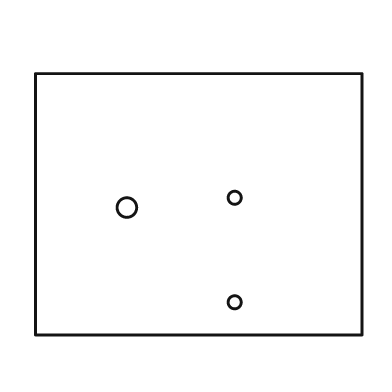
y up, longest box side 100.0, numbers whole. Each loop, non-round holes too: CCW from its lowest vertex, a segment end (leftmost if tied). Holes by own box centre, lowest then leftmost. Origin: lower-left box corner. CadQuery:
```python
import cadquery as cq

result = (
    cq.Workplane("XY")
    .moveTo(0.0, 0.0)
    .lineTo(100.0, 0.0)
    .lineTo(100.0, 80.0)
    .lineTo(0.0, 80.0)
    .close()
    .moveTo(61.0, 10.0)
    .circle(2.0)
    .moveTo(28.0, 39.0)
    .circle(3.0)
    .moveTo(61.0, 42.0)
    .circle(2.0)
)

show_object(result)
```